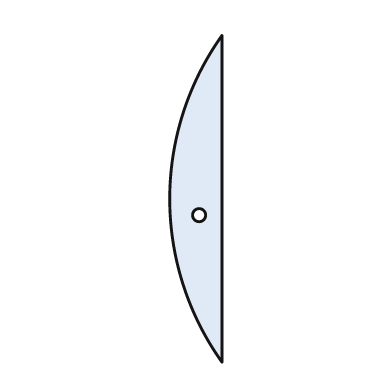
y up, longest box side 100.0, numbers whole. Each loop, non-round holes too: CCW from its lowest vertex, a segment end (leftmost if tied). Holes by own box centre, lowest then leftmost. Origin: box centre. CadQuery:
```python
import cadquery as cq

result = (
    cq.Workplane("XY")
    .moveTo(8.0, -50.0)
    .lineTo(8.0, 50.0)
    .threePointArc((-8.0, 0.0), (8.0, -50.0))
    .close()
    .moveTo(1.0, -5.0)
    .circle(2.0)
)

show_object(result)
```